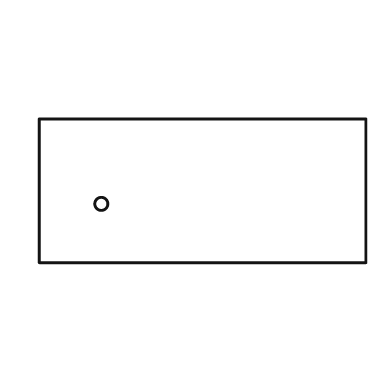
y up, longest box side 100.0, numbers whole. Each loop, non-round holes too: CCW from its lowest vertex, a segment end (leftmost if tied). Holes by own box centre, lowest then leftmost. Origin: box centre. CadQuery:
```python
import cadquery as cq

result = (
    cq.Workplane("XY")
    .moveTo(-50.0, -22.0)
    .lineTo(50.0, -22.0)
    .lineTo(50.0, 22.0)
    .lineTo(-50.0, 22.0)
    .close()
    .moveTo(-31.0, -4.0)
    .circle(2.0)
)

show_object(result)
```